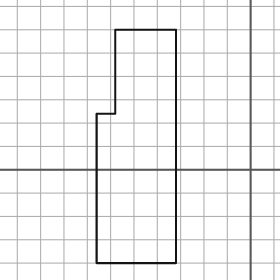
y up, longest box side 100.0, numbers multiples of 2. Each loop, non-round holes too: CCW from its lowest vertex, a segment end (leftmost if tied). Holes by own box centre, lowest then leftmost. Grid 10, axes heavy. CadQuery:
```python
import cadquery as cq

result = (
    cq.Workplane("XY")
    .moveTo(-66.0, -40.0)
    .lineTo(-32.0, -40.0)
    .lineTo(-32.0, 60.0)
    .lineTo(-58.0, 60.0)
    .lineTo(-58.0, 24.0)
    .lineTo(-66.0, 24.0)
    .close()
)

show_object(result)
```